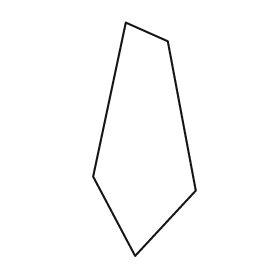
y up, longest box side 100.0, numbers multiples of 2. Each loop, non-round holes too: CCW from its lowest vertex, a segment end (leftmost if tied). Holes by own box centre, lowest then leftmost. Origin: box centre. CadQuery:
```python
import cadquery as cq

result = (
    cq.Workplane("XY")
    .moveTo(-4.0, -50.0)
    .lineTo(22.0, -22.0)
    .lineTo(10.0, 42.0)
    .lineTo(-8.0, 50.0)
    .lineTo(-22.0, -16.0)
    .close()
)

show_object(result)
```